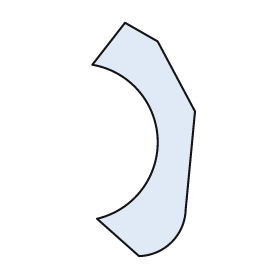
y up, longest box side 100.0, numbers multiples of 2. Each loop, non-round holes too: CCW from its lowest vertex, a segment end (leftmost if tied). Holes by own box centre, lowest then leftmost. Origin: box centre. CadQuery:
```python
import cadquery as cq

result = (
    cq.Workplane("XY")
    .moveTo(-2.0, -50.0)
    .threePointArc((12.0, -44.0), (18.0, -30.0))
    .lineTo(22.0, 12.0)
    .lineTo(6.0, 42.0)
    .lineTo(-8.0, 50.0)
    .lineTo(-22.0, 32.0)
    .threePointArc((6.0, 0.0), (-20.0, -34.0))
    .close()
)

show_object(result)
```